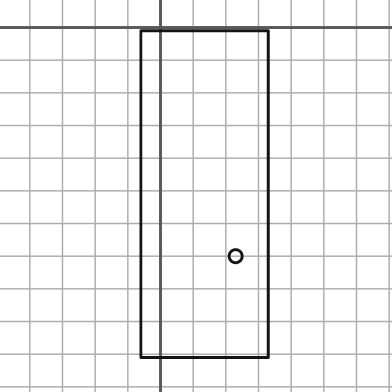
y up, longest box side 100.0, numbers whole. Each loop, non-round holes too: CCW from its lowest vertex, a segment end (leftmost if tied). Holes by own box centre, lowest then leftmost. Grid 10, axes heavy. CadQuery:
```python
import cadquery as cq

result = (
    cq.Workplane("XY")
    .moveTo(-6.0, -101.0)
    .lineTo(33.0, -101.0)
    .lineTo(33.0, -1.0)
    .lineTo(-6.0, -1.0)
    .close()
    .moveTo(23.0, -70.0)
    .circle(2.0)
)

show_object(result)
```